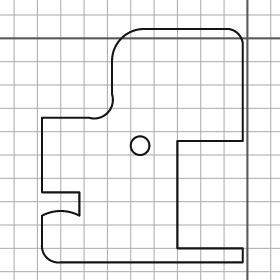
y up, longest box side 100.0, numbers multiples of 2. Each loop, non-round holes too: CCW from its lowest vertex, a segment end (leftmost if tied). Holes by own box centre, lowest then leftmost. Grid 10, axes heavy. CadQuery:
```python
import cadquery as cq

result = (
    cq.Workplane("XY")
    .moveTo(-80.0, -96.0)
    .lineTo(-2.0, -96.0)
    .lineTo(-2.0, -90.0)
    .lineTo(-30.0, -90.0)
    .lineTo(-30.0, -44.0)
    .lineTo(-2.0, -44.0)
    .lineTo(-2.0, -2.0)
    .threePointArc((-4.0, 2.0), (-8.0, 4.0))
    .lineTo(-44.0, 4.0)
    .threePointArc((-54.0, 0.0), (-58.0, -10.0))
    .lineTo(-58.0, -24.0)
    .threePointArc((-60.0, -32.0), (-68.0, -34.0))
    .lineTo(-88.0, -34.0)
    .lineTo(-88.0, -66.0)
    .lineTo(-72.0, -66.0)
    .lineTo(-72.0, -76.0)
    .threePointArc((-80.0, -74.0), (-88.0, -76.0))
    .lineTo(-88.0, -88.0)
    .threePointArc((-86.0, -94.0), (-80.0, -96.0))
    .close()
    .moveTo(-46.0, -46.0)
    .circle(4.0)
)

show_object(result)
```